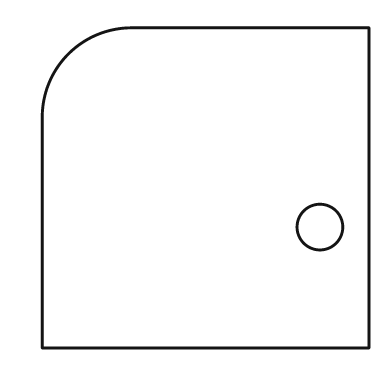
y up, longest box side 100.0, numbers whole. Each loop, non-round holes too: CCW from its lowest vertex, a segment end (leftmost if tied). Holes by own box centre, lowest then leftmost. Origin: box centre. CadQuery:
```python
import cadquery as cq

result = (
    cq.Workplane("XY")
    .moveTo(-50.0, -49.0)
    .lineTo(50.0, -49.0)
    .lineTo(50.0, 49.0)
    .lineTo(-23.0, 49.0)
    .threePointArc((-42.0, 41.0), (-50.0, 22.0))
    .close()
    .moveTo(35.0, -12.0)
    .circle(7.0)
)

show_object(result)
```